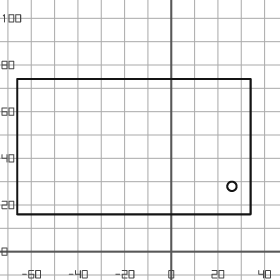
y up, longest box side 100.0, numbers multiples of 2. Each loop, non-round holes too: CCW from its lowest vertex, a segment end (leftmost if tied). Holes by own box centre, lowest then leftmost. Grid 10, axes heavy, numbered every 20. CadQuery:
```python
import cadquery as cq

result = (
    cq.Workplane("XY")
    .moveTo(-66.0, 16.0)
    .lineTo(34.0, 16.0)
    .lineTo(34.0, 74.0)
    .lineTo(-66.0, 74.0)
    .close()
    .moveTo(26.0, 28.0)
    .circle(2.0)
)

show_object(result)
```